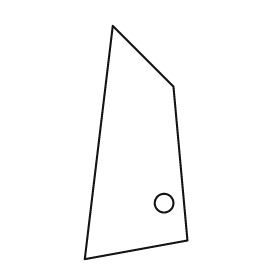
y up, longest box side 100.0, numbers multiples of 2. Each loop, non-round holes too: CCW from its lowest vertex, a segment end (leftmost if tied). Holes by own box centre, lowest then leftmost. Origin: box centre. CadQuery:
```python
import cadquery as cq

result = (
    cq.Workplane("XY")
    .moveTo(-22.0, -50.0)
    .lineTo(22.0, -42.0)
    .lineTo(16.0, 24.0)
    .lineTo(-10.0, 50.0)
    .close()
    .moveTo(12.0, -26.0)
    .circle(4.0)
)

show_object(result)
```